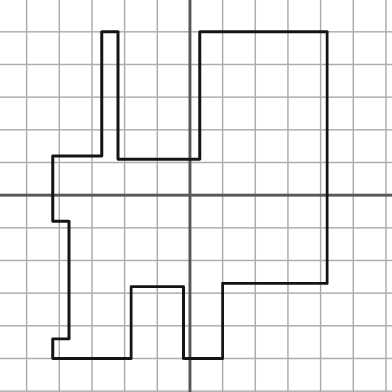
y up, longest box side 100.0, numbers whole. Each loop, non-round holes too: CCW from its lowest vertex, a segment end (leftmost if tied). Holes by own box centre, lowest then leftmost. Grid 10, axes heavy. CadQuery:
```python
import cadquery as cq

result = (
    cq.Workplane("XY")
    .moveTo(-42.0, -50.0)
    .lineTo(-18.0, -50.0)
    .lineTo(-18.0, -28.0)
    .lineTo(-2.0, -28.0)
    .lineTo(-2.0, -50.0)
    .lineTo(10.0, -50.0)
    .lineTo(10.0, -27.0)
    .lineTo(42.0, -27.0)
    .lineTo(42.0, 50.0)
    .lineTo(3.0, 50.0)
    .lineTo(3.0, 11.0)
    .lineTo(-22.0, 11.0)
    .lineTo(-22.0, 50.0)
    .lineTo(-27.0, 50.0)
    .lineTo(-27.0, 12.0)
    .lineTo(-42.0, 12.0)
    .lineTo(-42.0, -8.0)
    .lineTo(-37.0, -8.0)
    .lineTo(-37.0, -44.0)
    .lineTo(-42.0, -44.0)
    .close()
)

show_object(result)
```